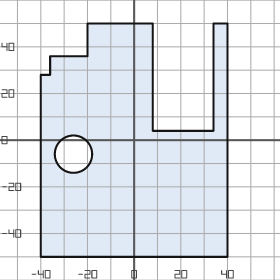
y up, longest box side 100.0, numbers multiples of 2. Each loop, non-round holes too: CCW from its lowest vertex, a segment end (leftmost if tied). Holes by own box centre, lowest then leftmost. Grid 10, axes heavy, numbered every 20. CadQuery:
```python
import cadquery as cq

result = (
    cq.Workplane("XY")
    .moveTo(-40.0, -50.0)
    .lineTo(40.0, -50.0)
    .lineTo(40.0, 50.0)
    .lineTo(34.0, 50.0)
    .lineTo(34.0, 4.0)
    .lineTo(8.0, 4.0)
    .lineTo(8.0, 50.0)
    .lineTo(-20.0, 50.0)
    .lineTo(-20.0, 36.0)
    .lineTo(-36.0, 36.0)
    .lineTo(-36.0, 28.0)
    .lineTo(-40.0, 28.0)
    .close()
    .moveTo(-26.0, -6.0)
    .circle(8.0)
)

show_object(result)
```